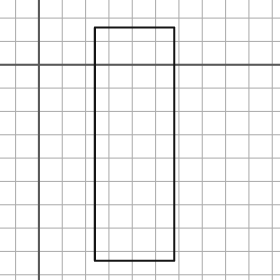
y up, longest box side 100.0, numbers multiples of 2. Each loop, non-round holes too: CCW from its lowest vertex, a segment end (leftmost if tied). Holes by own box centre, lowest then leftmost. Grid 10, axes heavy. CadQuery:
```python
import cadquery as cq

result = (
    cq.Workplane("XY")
    .moveTo(24.0, -84.0)
    .lineTo(58.0, -84.0)
    .lineTo(58.0, 16.0)
    .lineTo(24.0, 16.0)
    .close()
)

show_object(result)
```